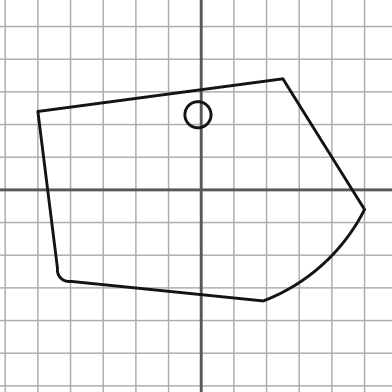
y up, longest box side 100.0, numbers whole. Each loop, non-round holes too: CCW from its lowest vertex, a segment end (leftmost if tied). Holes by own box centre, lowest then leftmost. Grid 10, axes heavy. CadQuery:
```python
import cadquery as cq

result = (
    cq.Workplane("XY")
    .moveTo(19.0, -34.0)
    .threePointArc((37.0, -23.0), (50.0, -6.0))
    .lineTo(25.0, 34.0)
    .lineTo(-50.0, 24.0)
    .lineTo(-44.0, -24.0)
    .threePointArc((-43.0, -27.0), (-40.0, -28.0))
    .close()
    .moveTo(-1.0, 23.0)
    .circle(4.0)
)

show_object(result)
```